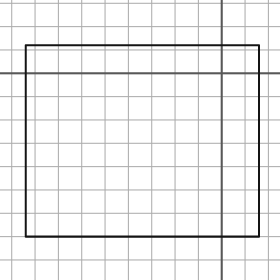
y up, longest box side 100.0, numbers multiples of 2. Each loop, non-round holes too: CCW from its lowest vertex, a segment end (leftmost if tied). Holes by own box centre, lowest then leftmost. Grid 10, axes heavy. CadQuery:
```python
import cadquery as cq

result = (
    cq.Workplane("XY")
    .moveTo(-84.0, -70.0)
    .lineTo(16.0, -70.0)
    .lineTo(16.0, 12.0)
    .lineTo(-84.0, 12.0)
    .close()
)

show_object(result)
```